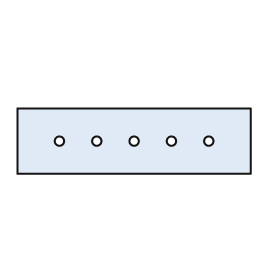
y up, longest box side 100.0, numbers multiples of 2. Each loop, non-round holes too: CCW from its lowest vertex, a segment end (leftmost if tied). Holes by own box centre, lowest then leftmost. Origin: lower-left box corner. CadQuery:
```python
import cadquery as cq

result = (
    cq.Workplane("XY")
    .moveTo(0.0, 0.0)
    .lineTo(100.0, 0.0)
    .lineTo(100.0, 28.0)
    .lineTo(0.0, 28.0)
    .close()
    .moveTo(18.0, 14.0)
    .circle(2.0)
    .moveTo(34.0, 14.0)
    .circle(2.0)
    .moveTo(50.0, 14.0)
    .circle(2.0)
    .moveTo(66.0, 14.0)
    .circle(2.0)
    .moveTo(82.0, 14.0)
    .circle(2.0)
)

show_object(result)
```